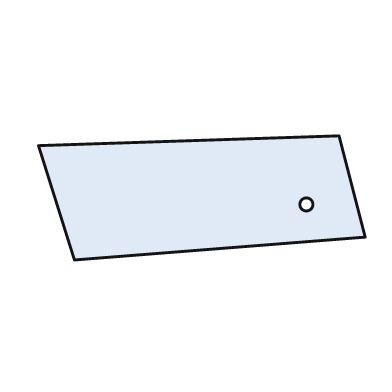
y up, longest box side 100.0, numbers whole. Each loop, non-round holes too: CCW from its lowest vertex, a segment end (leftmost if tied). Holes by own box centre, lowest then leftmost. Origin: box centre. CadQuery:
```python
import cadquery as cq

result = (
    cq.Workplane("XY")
    .moveTo(-39.0, -19.0)
    .lineTo(50.0, -12.0)
    .lineTo(42.0, 19.0)
    .lineTo(-50.0, 16.0)
    .close()
    .moveTo(32.0, -2.0)
    .circle(2.0)
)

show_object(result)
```